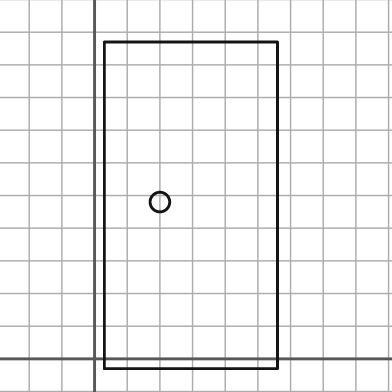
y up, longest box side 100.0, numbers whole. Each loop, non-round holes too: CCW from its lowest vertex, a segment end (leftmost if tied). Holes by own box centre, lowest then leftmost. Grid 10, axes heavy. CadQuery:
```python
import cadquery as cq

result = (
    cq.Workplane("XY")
    .moveTo(3.0, -3.0)
    .lineTo(56.0, -3.0)
    .lineTo(56.0, 97.0)
    .lineTo(3.0, 97.0)
    .close()
    .moveTo(20.0, 48.0)
    .circle(3.0)
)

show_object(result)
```